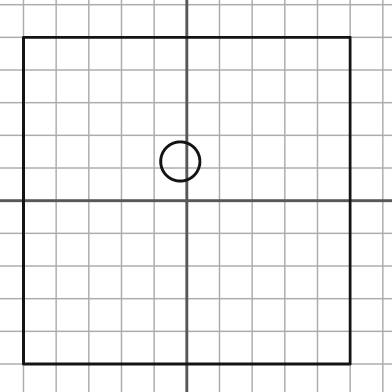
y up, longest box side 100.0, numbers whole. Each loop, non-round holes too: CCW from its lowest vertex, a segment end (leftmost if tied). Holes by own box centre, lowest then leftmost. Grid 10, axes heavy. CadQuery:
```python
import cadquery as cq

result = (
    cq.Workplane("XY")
    .moveTo(-50.0, -50.0)
    .lineTo(50.0, -50.0)
    .lineTo(50.0, 50.0)
    .lineTo(-50.0, 50.0)
    .close()
    .moveTo(-2.0, 12.0)
    .circle(6.0)
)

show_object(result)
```